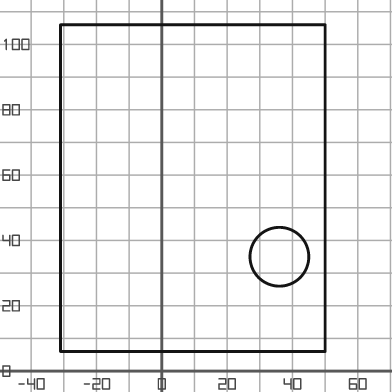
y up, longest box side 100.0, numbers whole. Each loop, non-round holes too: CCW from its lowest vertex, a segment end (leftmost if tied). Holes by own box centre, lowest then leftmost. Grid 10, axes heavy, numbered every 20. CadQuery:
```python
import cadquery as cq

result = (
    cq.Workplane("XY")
    .moveTo(-31.0, 6.0)
    .lineTo(50.0, 6.0)
    .lineTo(50.0, 106.0)
    .lineTo(-31.0, 106.0)
    .close()
    .moveTo(36.0, 35.0)
    .circle(9.0)
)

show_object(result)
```